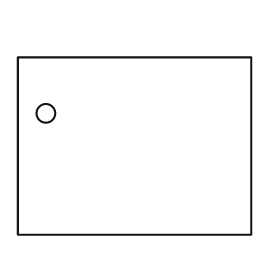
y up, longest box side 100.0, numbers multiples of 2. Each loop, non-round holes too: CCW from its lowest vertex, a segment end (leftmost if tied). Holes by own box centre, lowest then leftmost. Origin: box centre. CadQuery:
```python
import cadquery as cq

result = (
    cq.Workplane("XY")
    .moveTo(-50.0, -38.0)
    .lineTo(50.0, -38.0)
    .lineTo(50.0, 38.0)
    .lineTo(-50.0, 38.0)
    .close()
    .moveTo(-38.0, 14.0)
    .circle(4.0)
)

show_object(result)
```